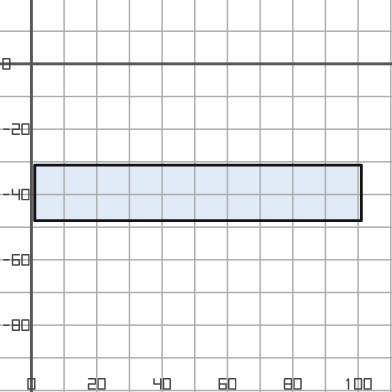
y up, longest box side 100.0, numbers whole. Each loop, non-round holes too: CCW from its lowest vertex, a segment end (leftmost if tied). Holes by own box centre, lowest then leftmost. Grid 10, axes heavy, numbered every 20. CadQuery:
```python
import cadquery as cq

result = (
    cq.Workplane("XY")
    .moveTo(1.0, -48.0)
    .lineTo(101.0, -48.0)
    .lineTo(101.0, -31.0)
    .lineTo(1.0, -31.0)
    .close()
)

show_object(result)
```